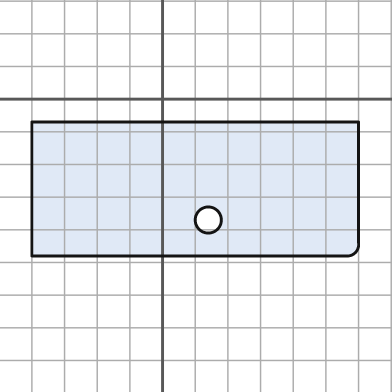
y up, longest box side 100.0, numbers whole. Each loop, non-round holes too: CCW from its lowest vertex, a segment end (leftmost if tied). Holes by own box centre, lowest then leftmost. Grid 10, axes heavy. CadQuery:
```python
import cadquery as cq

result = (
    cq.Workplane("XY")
    .moveTo(-40.0, -48.0)
    .lineTo(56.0, -48.0)
    .threePointArc((59.0, -47.0), (60.0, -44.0))
    .lineTo(60.0, -7.0)
    .lineTo(-40.0, -7.0)
    .close()
    .moveTo(14.0, -37.0)
    .circle(4.0)
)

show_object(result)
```